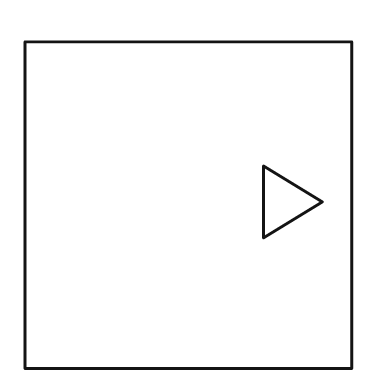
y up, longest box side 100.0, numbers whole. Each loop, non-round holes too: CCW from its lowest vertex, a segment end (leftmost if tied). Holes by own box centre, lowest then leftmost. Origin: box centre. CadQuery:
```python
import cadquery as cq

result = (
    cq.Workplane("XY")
    .moveTo(-50.0, -50.0)
    .lineTo(50.0, -50.0)
    .lineTo(50.0, 50.0)
    .lineTo(-50.0, 50.0)
    .close()
    .moveTo(23.0, -10.0)
    .lineTo(41.0, 1.0)
    .lineTo(23.0, 12.0)
    .close()
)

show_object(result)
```